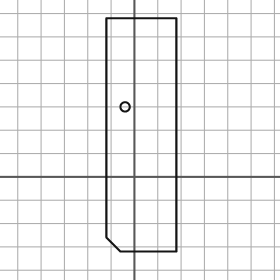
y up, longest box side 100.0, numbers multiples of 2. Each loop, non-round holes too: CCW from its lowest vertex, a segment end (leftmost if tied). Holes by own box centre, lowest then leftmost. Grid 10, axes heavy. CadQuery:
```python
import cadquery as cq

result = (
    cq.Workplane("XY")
    .moveTo(-6.0, -32.0)
    .lineTo(18.0, -32.0)
    .lineTo(18.0, 68.0)
    .lineTo(-12.0, 68.0)
    .lineTo(-12.0, -26.0)
    .close()
    .moveTo(-4.0, 30.0)
    .circle(2.0)
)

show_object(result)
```